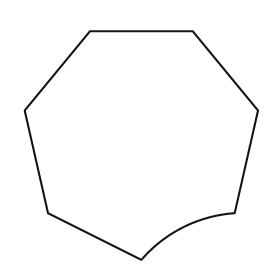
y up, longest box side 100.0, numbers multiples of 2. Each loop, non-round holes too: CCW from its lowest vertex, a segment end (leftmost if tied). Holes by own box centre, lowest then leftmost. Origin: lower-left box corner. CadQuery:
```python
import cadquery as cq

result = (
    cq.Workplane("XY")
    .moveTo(50.0, 0.0)
    .threePointArc((68.0, 14.0), (90.0, 20.0))
    .lineTo(100.0, 64.0)
    .lineTo(72.0, 98.0)
    .lineTo(28.0, 98.0)
    .lineTo(0.0, 64.0)
    .lineTo(10.0, 20.0)
    .close()
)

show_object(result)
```